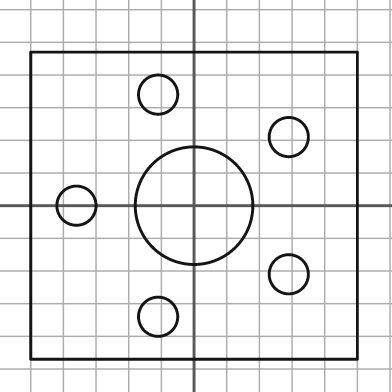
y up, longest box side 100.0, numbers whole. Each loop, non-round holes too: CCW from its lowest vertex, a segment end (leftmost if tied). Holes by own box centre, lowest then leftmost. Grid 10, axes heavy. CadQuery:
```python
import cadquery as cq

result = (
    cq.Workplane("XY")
    .moveTo(-50.0, -47.0)
    .lineTo(50.0, -47.0)
    .lineTo(50.0, 47.0)
    .lineTo(-50.0, 47.0)
    .close()
    .moveTo(-11.0, -34.0)
    .circle(6.0)
    .moveTo(29.0, -21.0)
    .circle(6.0)
    .moveTo(-36.0, 0.0)
    .circle(6.0)
    .moveTo(0.0, 0.0)
    .circle(18.0)
    .moveTo(29.0, 21.0)
    .circle(6.0)
    .moveTo(-11.0, 34.0)
    .circle(6.0)
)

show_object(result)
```